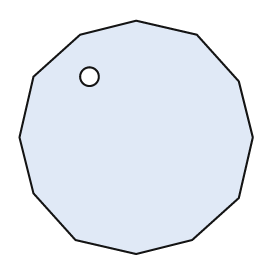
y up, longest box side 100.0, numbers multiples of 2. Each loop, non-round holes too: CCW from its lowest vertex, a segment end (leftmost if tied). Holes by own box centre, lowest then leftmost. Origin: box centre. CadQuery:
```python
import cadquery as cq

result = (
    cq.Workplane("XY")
    .moveTo(0.0, -50.0)
    .lineTo(24.0, -44.0)
    .lineTo(44.0, -26.0)
    .lineTo(50.0, 0.0)
    .lineTo(44.0, 24.0)
    .lineTo(26.0, 44.0)
    .lineTo(0.0, 50.0)
    .lineTo(-24.0, 44.0)
    .lineTo(-44.0, 26.0)
    .lineTo(-50.0, 0.0)
    .lineTo(-44.0, -24.0)
    .lineTo(-26.0, -44.0)
    .close()
    .moveTo(-20.0, 26.0)
    .circle(4.0)
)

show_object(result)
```